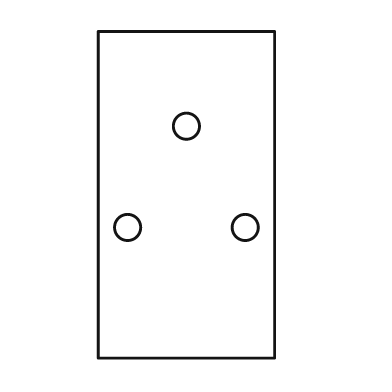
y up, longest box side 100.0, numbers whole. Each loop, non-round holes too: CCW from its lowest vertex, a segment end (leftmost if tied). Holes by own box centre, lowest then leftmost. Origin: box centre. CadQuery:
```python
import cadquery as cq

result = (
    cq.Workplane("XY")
    .moveTo(-27.0, -50.0)
    .lineTo(27.0, -50.0)
    .lineTo(27.0, 50.0)
    .lineTo(-27.0, 50.0)
    .close()
    .moveTo(-18.0, -10.0)
    .circle(4.0)
    .moveTo(18.0, -10.0)
    .circle(4.0)
    .moveTo(0.0, 21.0)
    .circle(4.0)
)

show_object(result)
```